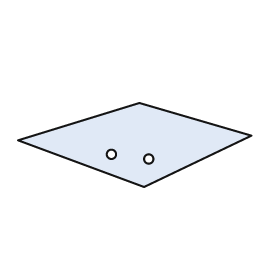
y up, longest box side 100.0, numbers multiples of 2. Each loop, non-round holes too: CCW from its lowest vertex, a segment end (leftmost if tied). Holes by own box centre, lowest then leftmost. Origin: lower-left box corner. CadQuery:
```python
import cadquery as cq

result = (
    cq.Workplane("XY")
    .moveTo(54.0, 0.0)
    .lineTo(100.0, 22.0)
    .lineTo(52.0, 36.0)
    .lineTo(0.0, 20.0)
    .close()
    .moveTo(56.0, 12.0)
    .circle(2.0)
    .moveTo(40.0, 14.0)
    .circle(2.0)
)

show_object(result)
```